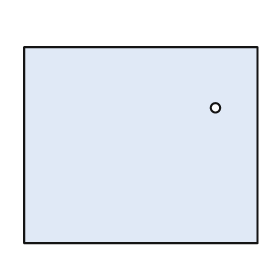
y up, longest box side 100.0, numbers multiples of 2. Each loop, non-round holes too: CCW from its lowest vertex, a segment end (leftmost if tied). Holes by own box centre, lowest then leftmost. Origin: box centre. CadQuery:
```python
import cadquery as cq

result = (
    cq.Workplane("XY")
    .moveTo(-50.0, -42.0)
    .lineTo(50.0, -42.0)
    .lineTo(50.0, 42.0)
    .lineTo(-50.0, 42.0)
    .close()
    .moveTo(32.0, 16.0)
    .circle(2.0)
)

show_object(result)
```